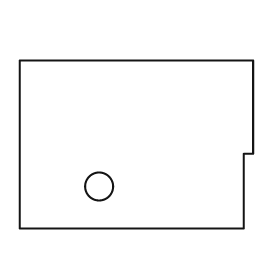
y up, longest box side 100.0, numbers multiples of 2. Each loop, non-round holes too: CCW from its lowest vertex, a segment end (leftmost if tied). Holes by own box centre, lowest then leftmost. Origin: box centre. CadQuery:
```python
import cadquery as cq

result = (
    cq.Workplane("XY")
    .moveTo(-50.0, -36.0)
    .lineTo(46.0, -36.0)
    .lineTo(46.0, -4.0)
    .lineTo(50.0, -4.0)
    .lineTo(50.0, 36.0)
    .lineTo(-50.0, 36.0)
    .close()
    .moveTo(-16.0, -18.0)
    .circle(6.0)
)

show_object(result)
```